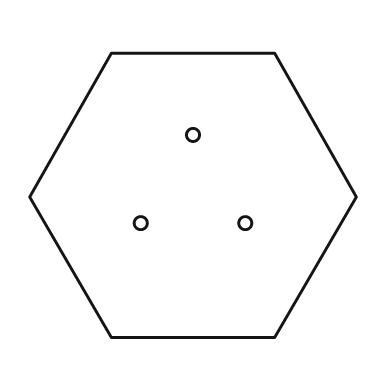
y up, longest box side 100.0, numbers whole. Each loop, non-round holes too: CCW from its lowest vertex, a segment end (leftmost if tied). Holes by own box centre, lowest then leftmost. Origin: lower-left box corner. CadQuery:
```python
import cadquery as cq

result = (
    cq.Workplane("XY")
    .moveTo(25.0, 0.0)
    .lineTo(75.0, 0.0)
    .lineTo(100.0, 43.0)
    .lineTo(75.0, 87.0)
    .lineTo(25.0, 87.0)
    .lineTo(0.0, 43.0)
    .close()
    .moveTo(34.0, 35.0)
    .circle(2.0)
    .moveTo(66.0, 35.0)
    .circle(2.0)
    .moveTo(50.0, 62.0)
    .circle(2.0)
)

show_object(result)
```